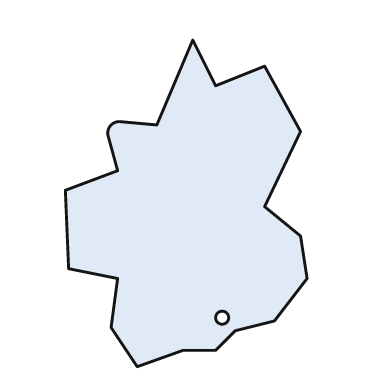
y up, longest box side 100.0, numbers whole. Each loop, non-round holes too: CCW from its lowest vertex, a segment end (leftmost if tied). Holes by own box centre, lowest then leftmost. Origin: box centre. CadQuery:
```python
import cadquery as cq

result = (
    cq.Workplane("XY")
    .moveTo(-15.0, -50.0)
    .lineTo(-1.0, -45.0)
    .lineTo(9.0, -45.0)
    .lineTo(15.0, -39.0)
    .lineTo(27.0, -36.0)
    .lineTo(37.0, -23.0)
    .lineTo(35.0, -10.0)
    .lineTo(24.0, -1.0)
    .lineTo(35.0, 22.0)
    .lineTo(24.0, 42.0)
    .lineTo(9.0, 36.0)
    .lineTo(2.0, 50.0)
    .lineTo(-9.0, 24.0)
    .lineTo(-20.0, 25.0)
    .threePointArc((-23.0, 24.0), (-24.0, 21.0))
    .lineTo(-21.0, 10.0)
    .lineTo(-37.0, 4.0)
    .lineTo(-36.0, -20.0)
    .lineTo(-21.0, -23.0)
    .lineTo(-23.0, -38.0)
    .close()
    .moveTo(11.0, -35.0)
    .circle(2.0)
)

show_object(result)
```